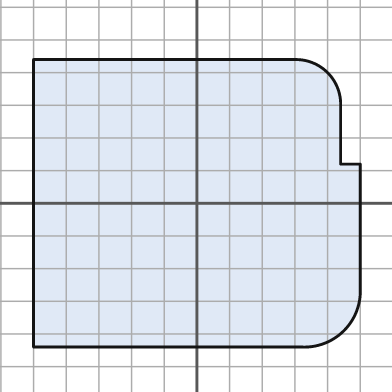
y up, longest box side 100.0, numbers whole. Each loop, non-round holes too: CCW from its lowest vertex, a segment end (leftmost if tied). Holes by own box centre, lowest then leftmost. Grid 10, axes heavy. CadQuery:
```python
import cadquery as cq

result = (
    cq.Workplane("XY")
    .moveTo(-50.0, -44.0)
    .lineTo(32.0, -44.0)
    .threePointArc((45.0, -39.0), (50.0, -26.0))
    .lineTo(50.0, 12.0)
    .lineTo(44.0, 12.0)
    .lineTo(44.0, 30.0)
    .threePointArc((40.0, 40.0), (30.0, 44.0))
    .lineTo(-50.0, 44.0)
    .close()
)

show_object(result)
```